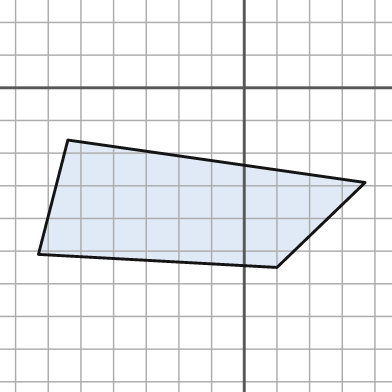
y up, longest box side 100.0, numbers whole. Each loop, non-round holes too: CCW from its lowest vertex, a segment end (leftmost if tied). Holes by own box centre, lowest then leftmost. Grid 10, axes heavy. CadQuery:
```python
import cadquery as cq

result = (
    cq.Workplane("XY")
    .moveTo(10.0, -55.0)
    .lineTo(37.0, -29.0)
    .lineTo(-54.0, -16.0)
    .lineTo(-63.0, -51.0)
    .close()
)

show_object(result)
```